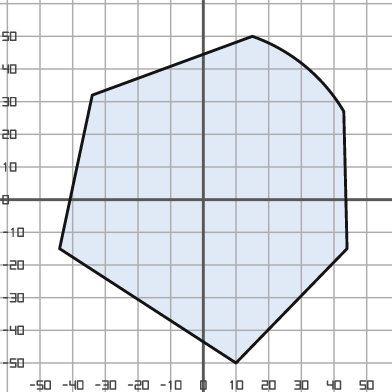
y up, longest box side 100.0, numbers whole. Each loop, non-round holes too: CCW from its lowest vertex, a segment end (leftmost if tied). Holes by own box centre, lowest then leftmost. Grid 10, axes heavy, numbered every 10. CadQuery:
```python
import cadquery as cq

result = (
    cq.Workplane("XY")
    .moveTo(10.0, -50.0)
    .lineTo(44.0, -15.0)
    .lineTo(43.0, 27.0)
    .threePointArc((31.0, 41.0), (15.0, 50.0))
    .lineTo(-34.0, 32.0)
    .lineTo(-44.0, -15.0)
    .close()
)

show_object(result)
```